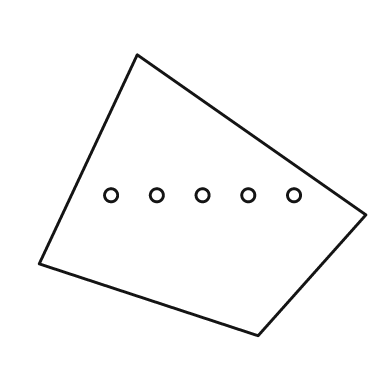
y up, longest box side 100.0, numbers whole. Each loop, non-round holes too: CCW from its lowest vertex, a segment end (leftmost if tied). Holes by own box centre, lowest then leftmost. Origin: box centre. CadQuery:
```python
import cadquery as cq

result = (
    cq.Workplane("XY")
    .moveTo(17.0, -43.0)
    .lineTo(50.0, -6.0)
    .lineTo(-20.0, 43.0)
    .lineTo(-50.0, -21.0)
    .close()
    .moveTo(-28.0, 0.0)
    .circle(2.0)
    .moveTo(-14.0, 0.0)
    .circle(2.0)
    .moveTo(0.0, 0.0)
    .circle(2.0)
    .moveTo(14.0, 0.0)
    .circle(2.0)
    .moveTo(28.0, 0.0)
    .circle(2.0)
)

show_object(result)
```